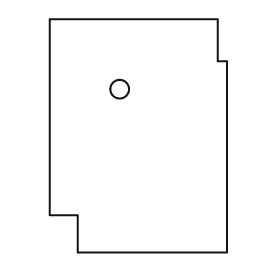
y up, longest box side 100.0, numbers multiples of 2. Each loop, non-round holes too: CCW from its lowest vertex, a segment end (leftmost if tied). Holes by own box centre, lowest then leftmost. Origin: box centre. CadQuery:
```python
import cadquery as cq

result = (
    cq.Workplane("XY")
    .moveTo(-26.0, -50.0)
    .lineTo(38.0, -50.0)
    .lineTo(38.0, 32.0)
    .lineTo(34.0, 32.0)
    .lineTo(34.0, 50.0)
    .lineTo(-38.0, 50.0)
    .lineTo(-38.0, -34.0)
    .lineTo(-26.0, -34.0)
    .close()
    .moveTo(-8.0, 20.0)
    .circle(4.0)
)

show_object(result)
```